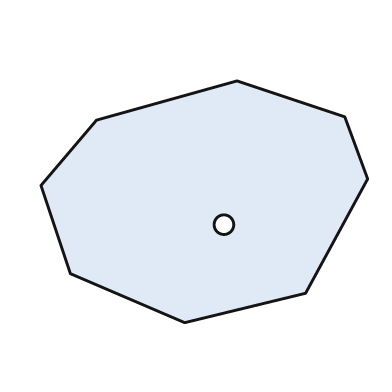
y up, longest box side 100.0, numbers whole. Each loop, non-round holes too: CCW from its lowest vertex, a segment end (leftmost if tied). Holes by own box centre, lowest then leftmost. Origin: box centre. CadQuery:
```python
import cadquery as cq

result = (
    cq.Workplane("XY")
    .moveTo(-6.0, -37.0)
    .lineTo(31.0, -28.0)
    .lineTo(50.0, 7.0)
    .lineTo(43.0, 26.0)
    .lineTo(10.0, 37.0)
    .lineTo(-33.0, 25.0)
    .lineTo(-50.0, 5.0)
    .lineTo(-41.0, -22.0)
    .close()
    .moveTo(6.0, -7.0)
    .circle(3.0)
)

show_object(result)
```